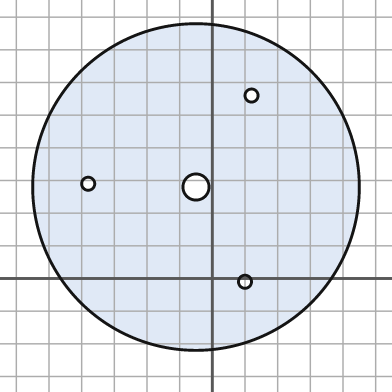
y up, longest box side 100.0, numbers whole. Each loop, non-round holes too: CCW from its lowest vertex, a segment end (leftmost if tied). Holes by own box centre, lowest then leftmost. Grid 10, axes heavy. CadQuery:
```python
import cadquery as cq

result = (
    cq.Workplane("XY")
    .moveTo(-5.0, 28.0)
    .circle(50.0)
    .moveTo(10.0, -1.0)
    .circle(2.0)
    .moveTo(-5.0, 28.0)
    .circle(4.0)
    .moveTo(-38.0, 29.0)
    .circle(2.0)
    .moveTo(12.0, 56.0)
    .circle(2.0)
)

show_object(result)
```